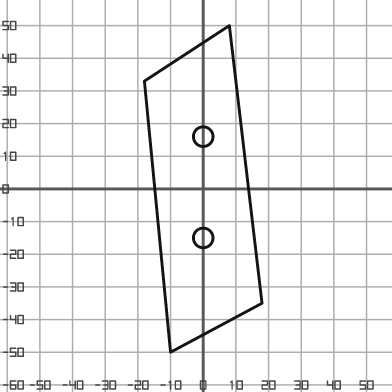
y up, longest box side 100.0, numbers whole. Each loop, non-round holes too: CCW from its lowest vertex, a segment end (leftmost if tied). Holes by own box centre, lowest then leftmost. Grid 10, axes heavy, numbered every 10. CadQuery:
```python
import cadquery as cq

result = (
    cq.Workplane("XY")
    .moveTo(-10.0, -50.0)
    .lineTo(18.0, -35.0)
    .lineTo(8.0, 50.0)
    .lineTo(-18.0, 33.0)
    .close()
    .moveTo(0.0, -15.0)
    .circle(3.0)
    .moveTo(0.0, 16.0)
    .circle(3.0)
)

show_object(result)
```